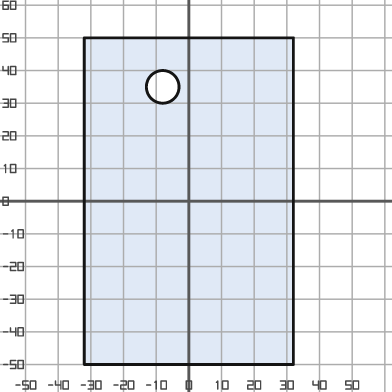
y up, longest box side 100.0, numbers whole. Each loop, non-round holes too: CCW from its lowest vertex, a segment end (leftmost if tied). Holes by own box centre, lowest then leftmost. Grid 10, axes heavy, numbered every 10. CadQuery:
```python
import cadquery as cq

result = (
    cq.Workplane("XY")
    .moveTo(-32.0, -50.0)
    .lineTo(32.0, -50.0)
    .lineTo(32.0, 50.0)
    .lineTo(-32.0, 50.0)
    .close()
    .moveTo(-8.0, 35.0)
    .circle(5.0)
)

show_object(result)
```